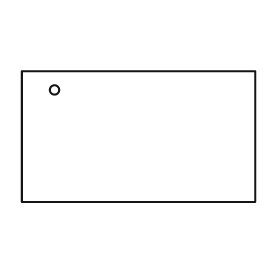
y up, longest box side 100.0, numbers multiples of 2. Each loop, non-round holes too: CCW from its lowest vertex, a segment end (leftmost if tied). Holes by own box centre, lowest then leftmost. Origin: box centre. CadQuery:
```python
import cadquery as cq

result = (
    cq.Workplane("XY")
    .moveTo(-50.0, -28.0)
    .lineTo(50.0, -28.0)
    .lineTo(50.0, 28.0)
    .lineTo(-50.0, 28.0)
    .close()
    .moveTo(-36.0, 20.0)
    .circle(2.0)
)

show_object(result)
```